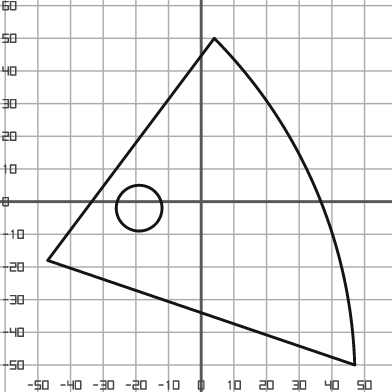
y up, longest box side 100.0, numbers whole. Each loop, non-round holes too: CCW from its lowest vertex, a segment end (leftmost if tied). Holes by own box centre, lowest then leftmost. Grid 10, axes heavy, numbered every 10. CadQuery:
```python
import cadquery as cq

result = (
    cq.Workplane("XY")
    .moveTo(47.0, -50.0)
    .threePointArc((35.0, 4.0), (4.0, 50.0))
    .lineTo(-47.0, -18.0)
    .close()
    .moveTo(-19.0, -2.0)
    .circle(7.0)
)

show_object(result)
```